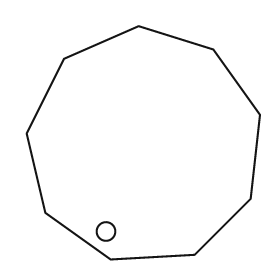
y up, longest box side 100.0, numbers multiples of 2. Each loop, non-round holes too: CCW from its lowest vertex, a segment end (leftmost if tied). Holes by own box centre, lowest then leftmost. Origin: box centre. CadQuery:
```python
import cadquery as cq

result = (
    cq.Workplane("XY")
    .moveTo(-14.0, -50.0)
    .lineTo(22.0, -48.0)
    .lineTo(46.0, -24.0)
    .lineTo(50.0, 12.0)
    .lineTo(30.0, 40.0)
    .lineTo(-2.0, 50.0)
    .lineTo(-34.0, 36.0)
    .lineTo(-50.0, 4.0)
    .lineTo(-42.0, -30.0)
    .close()
    .moveTo(-16.0, -38.0)
    .circle(4.0)
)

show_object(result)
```